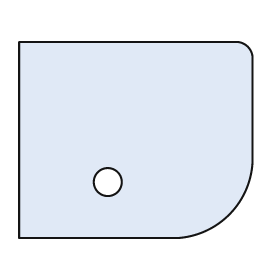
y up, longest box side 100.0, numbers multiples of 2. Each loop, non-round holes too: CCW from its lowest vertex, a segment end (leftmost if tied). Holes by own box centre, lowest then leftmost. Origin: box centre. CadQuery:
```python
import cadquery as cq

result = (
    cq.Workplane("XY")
    .moveTo(-50.0, -42.0)
    .lineTo(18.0, -42.0)
    .threePointArc((40.0, -32.0), (50.0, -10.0))
    .lineTo(50.0, 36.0)
    .threePointArc((48.0, 40.0), (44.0, 42.0))
    .lineTo(-50.0, 42.0)
    .close()
    .moveTo(-12.0, -18.0)
    .circle(6.0)
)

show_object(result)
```